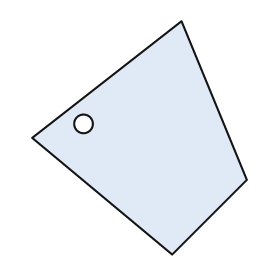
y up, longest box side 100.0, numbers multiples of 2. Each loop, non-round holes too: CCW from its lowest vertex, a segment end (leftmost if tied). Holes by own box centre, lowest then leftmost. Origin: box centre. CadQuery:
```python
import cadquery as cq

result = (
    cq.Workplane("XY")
    .moveTo(14.0, -50.0)
    .lineTo(46.0, -18.0)
    .lineTo(18.0, 50.0)
    .lineTo(-46.0, 0.0)
    .close()
    .moveTo(-24.0, 6.0)
    .circle(4.0)
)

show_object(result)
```